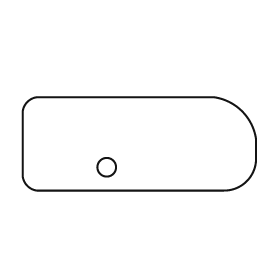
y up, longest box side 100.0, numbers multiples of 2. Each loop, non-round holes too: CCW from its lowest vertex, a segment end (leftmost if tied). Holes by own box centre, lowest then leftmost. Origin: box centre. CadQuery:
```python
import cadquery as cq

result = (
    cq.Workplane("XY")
    .moveTo(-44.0, -20.0)
    .lineTo(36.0, -20.0)
    .threePointArc((46.0, -16.0), (50.0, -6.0))
    .lineTo(50.0, 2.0)
    .threePointArc((44.0, 14.0), (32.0, 20.0))
    .lineTo(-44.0, 20.0)
    .threePointArc((-48.0, 18.0), (-50.0, 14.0))
    .lineTo(-50.0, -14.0)
    .threePointArc((-48.0, -18.0), (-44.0, -20.0))
    .close()
    .moveTo(-14.0, -10.0)
    .circle(4.0)
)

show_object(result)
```